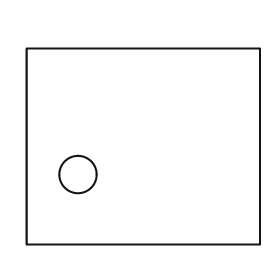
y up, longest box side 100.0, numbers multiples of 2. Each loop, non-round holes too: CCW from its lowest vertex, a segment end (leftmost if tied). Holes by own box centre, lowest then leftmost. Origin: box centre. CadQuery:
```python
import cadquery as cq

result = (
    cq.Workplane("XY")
    .moveTo(-50.0, -42.0)
    .lineTo(50.0, -42.0)
    .lineTo(50.0, 42.0)
    .lineTo(-50.0, 42.0)
    .close()
    .moveTo(-28.0, -12.0)
    .circle(8.0)
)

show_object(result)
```